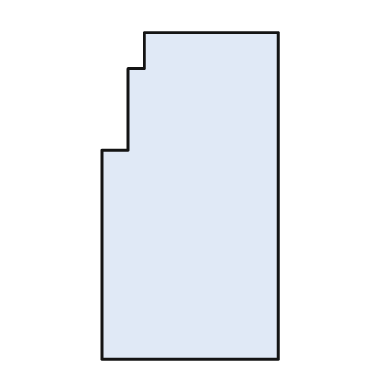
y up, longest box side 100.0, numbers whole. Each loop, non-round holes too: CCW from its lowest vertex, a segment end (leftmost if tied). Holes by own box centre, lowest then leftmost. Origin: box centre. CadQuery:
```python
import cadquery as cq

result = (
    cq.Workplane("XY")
    .moveTo(-27.0, -50.0)
    .lineTo(27.0, -50.0)
    .lineTo(27.0, 50.0)
    .lineTo(-14.0, 50.0)
    .lineTo(-14.0, 39.0)
    .lineTo(-19.0, 39.0)
    .lineTo(-19.0, 14.0)
    .lineTo(-27.0, 14.0)
    .close()
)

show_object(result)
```